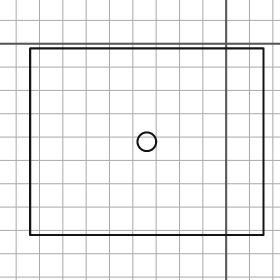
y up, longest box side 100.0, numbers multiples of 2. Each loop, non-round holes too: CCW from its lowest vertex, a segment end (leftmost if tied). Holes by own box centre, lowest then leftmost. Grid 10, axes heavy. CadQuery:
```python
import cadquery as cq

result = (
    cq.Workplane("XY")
    .moveTo(-84.0, -82.0)
    .lineTo(16.0, -82.0)
    .lineTo(16.0, -2.0)
    .lineTo(-84.0, -2.0)
    .close()
    .moveTo(-34.0, -42.0)
    .circle(4.0)
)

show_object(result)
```